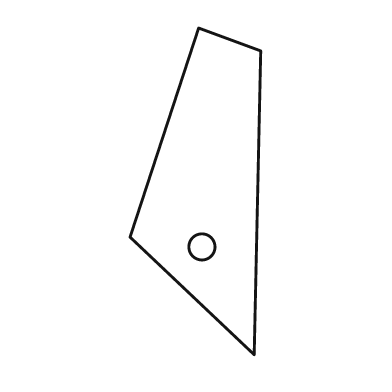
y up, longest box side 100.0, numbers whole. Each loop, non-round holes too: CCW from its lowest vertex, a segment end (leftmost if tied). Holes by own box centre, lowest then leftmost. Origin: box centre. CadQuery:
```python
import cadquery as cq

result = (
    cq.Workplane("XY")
    .moveTo(18.0, -50.0)
    .lineTo(20.0, 43.0)
    .lineTo(1.0, 50.0)
    .lineTo(-20.0, -14.0)
    .close()
    .moveTo(2.0, -17.0)
    .circle(4.0)
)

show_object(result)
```